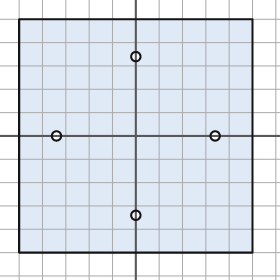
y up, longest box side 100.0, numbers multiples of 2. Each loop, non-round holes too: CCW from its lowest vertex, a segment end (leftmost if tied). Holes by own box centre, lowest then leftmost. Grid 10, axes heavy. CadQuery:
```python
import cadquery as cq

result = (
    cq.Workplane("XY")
    .moveTo(-50.0, -50.0)
    .lineTo(50.0, -50.0)
    .lineTo(50.0, 50.0)
    .lineTo(-50.0, 50.0)
    .close()
    .moveTo(0.0, -34.0)
    .circle(2.0)
    .moveTo(-34.0, 0.0)
    .circle(2.0)
    .moveTo(34.0, 0.0)
    .circle(2.0)
    .moveTo(0.0, 34.0)
    .circle(2.0)
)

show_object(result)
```